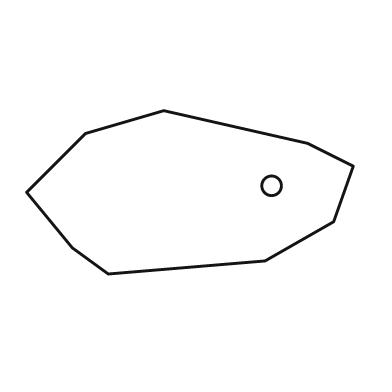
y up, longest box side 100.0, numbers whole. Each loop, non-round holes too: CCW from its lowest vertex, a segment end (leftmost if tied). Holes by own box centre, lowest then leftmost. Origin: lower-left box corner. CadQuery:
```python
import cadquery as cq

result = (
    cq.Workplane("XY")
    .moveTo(25.0, 0.0)
    .lineTo(73.0, 4.0)
    .lineTo(94.0, 16.0)
    .lineTo(100.0, 33.0)
    .lineTo(86.0, 40.0)
    .lineTo(42.0, 50.0)
    .lineTo(18.0, 43.0)
    .lineTo(0.0, 25.0)
    .lineTo(14.0, 8.0)
    .close()
    .moveTo(75.0, 27.0)
    .circle(3.0)
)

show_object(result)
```